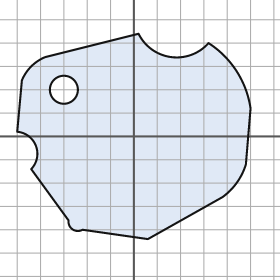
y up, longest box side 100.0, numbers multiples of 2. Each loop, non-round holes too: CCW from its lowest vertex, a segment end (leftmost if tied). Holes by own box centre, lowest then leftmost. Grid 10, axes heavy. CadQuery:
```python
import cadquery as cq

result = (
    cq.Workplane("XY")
    .moveTo(6.0, -44.0)
    .lineTo(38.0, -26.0)
    .threePointArc((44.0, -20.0), (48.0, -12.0))
    .lineTo(50.0, 12.0)
    .threePointArc((44.0, 28.0), (32.0, 40.0))
    .threePointArc((16.0, 34.0), (2.0, 44.0))
    .lineTo(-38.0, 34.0)
    .threePointArc((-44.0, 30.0), (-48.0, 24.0))
    .lineTo(-50.0, 2.0)
    .threePointArc((-42.0, -4.0), (-44.0, -14.0))
    .lineTo(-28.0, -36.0)
    .threePointArc((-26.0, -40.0), (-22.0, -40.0))
    .close()
    .moveTo(-30.0, 20.0)
    .circle(6.0)
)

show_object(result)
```